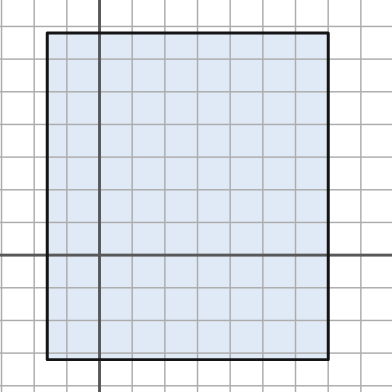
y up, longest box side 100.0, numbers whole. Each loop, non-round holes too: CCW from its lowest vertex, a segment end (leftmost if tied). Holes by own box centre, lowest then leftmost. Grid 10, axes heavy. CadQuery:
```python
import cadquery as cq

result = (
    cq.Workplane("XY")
    .moveTo(-16.0, -32.0)
    .lineTo(70.0, -32.0)
    .lineTo(70.0, 68.0)
    .lineTo(-16.0, 68.0)
    .close()
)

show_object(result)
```